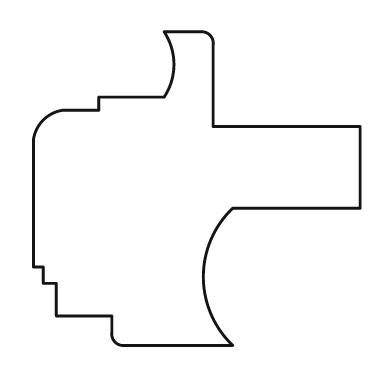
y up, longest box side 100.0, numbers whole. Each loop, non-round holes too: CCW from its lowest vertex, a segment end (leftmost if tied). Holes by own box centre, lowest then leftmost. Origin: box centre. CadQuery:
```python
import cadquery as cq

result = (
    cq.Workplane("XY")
    .moveTo(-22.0, -48.0)
    .lineTo(11.0, -48.0)
    .threePointArc((2.0, -27.0), (11.0, -6.0))
    .lineTo(50.0, -6.0)
    .lineTo(50.0, 19.0)
    .lineTo(5.0, 19.0)
    .lineTo(5.0, 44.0)
    .threePointArc((4.0, 47.0), (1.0, 48.0))
    .lineTo(-10.0, 48.0)
    .threePointArc((-7.0, 38.0), (-10.0, 28.0))
    .lineTo(-30.0, 28.0)
    .lineTo(-30.0, 24.0)
    .lineTo(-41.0, 24.0)
    .threePointArc((-47.0, 21.0), (-50.0, 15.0))
    .lineTo(-50.0, -24.0)
    .lineTo(-47.0, -24.0)
    .lineTo(-47.0, -29.0)
    .lineTo(-43.0, -29.0)
    .lineTo(-43.0, -39.0)
    .lineTo(-26.0, -39.0)
    .lineTo(-26.0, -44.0)
    .threePointArc((-25.0, -47.0), (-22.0, -48.0))
    .close()
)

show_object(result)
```